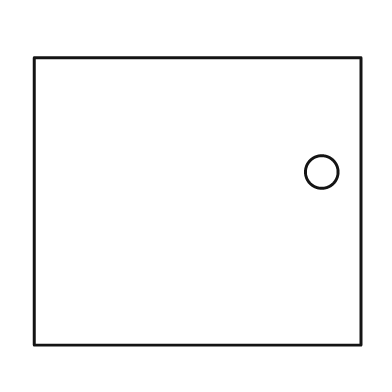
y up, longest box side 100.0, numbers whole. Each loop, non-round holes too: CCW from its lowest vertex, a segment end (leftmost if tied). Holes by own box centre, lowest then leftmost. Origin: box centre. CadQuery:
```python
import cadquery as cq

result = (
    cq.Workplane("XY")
    .moveTo(-50.0, -44.0)
    .lineTo(50.0, -44.0)
    .lineTo(50.0, 44.0)
    .lineTo(-50.0, 44.0)
    .close()
    .moveTo(38.0, 9.0)
    .circle(5.0)
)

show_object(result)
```